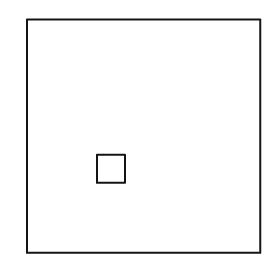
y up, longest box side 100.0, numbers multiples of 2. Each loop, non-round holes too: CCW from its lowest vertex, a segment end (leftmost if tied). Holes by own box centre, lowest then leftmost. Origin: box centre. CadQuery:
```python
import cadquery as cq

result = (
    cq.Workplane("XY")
    .moveTo(-50.0, -50.0)
    .lineTo(50.0, -50.0)
    .lineTo(50.0, 50.0)
    .lineTo(-50.0, 50.0)
    .close()
    .moveTo(-20.0, -20.0)
    .lineTo(-8.0, -20.0)
    .lineTo(-8.0, -8.0)
    .lineTo(-20.0, -8.0)
    .close()
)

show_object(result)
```